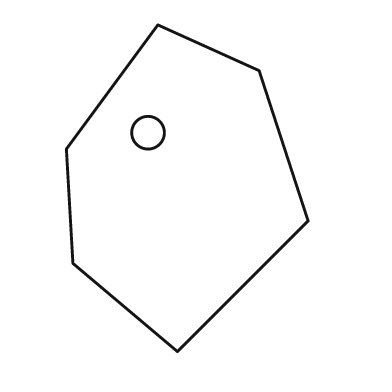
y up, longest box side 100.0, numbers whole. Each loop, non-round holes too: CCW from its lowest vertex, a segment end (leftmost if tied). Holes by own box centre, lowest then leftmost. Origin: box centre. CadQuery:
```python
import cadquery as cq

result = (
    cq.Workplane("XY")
    .moveTo(-3.0, -50.0)
    .lineTo(37.0, -10.0)
    .lineTo(22.0, 36.0)
    .lineTo(-9.0, 50.0)
    .lineTo(-37.0, 12.0)
    .lineTo(-35.0, -23.0)
    .close()
    .moveTo(-12.0, 17.0)
    .circle(5.0)
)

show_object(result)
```